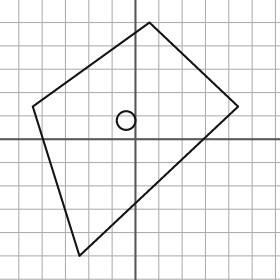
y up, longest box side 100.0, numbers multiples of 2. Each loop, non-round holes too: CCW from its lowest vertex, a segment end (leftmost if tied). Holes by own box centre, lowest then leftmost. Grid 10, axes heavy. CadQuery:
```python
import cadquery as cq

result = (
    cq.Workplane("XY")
    .moveTo(-24.0, -50.0)
    .lineTo(44.0, 14.0)
    .lineTo(6.0, 50.0)
    .lineTo(-44.0, 14.0)
    .close()
    .moveTo(-4.0, 8.0)
    .circle(4.0)
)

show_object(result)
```